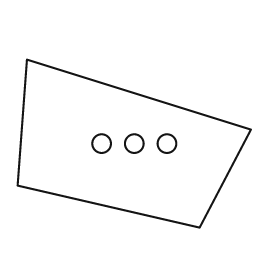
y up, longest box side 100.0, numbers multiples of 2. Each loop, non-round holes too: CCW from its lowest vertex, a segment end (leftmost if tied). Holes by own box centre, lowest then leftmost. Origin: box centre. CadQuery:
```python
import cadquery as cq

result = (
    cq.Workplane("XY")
    .moveTo(28.0, -36.0)
    .lineTo(50.0, 6.0)
    .lineTo(-46.0, 36.0)
    .lineTo(-50.0, -18.0)
    .close()
    .moveTo(-14.0, 0.0)
    .circle(4.0)
    .moveTo(0.0, 0.0)
    .circle(4.0)
    .moveTo(14.0, 0.0)
    .circle(4.0)
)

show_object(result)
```